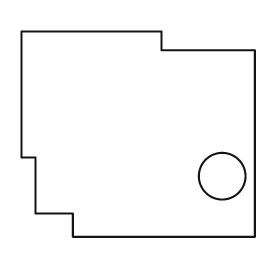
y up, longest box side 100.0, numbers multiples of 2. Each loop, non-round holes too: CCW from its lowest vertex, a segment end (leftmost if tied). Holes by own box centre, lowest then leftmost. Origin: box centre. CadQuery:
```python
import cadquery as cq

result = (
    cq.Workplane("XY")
    .moveTo(-28.0, -44.0)
    .lineTo(50.0, -44.0)
    .lineTo(50.0, 36.0)
    .lineTo(10.0, 36.0)
    .lineTo(10.0, 44.0)
    .lineTo(-50.0, 44.0)
    .lineTo(-50.0, -10.0)
    .lineTo(-44.0, -10.0)
    .lineTo(-44.0, -34.0)
    .lineTo(-28.0, -34.0)
    .close()
    .moveTo(36.0, -18.0)
    .circle(10.0)
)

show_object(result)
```